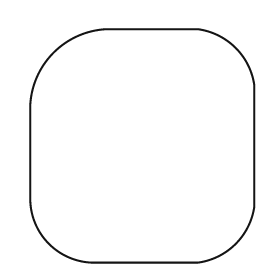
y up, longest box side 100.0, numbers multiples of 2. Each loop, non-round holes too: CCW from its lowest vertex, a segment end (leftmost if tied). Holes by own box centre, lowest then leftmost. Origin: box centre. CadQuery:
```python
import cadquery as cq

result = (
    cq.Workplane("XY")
    .moveTo(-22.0, -50.0)
    .lineTo(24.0, -50.0)
    .threePointArc((40.0, -42.0), (48.0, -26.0))
    .lineTo(48.0, 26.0)
    .threePointArc((40.0, 42.0), (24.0, 50.0))
    .lineTo(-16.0, 50.0)
    .threePointArc((-38.0, 40.0), (-48.0, 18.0))
    .lineTo(-48.0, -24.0)
    .threePointArc((-40.0, -42.0), (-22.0, -50.0))
    .close()
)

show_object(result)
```